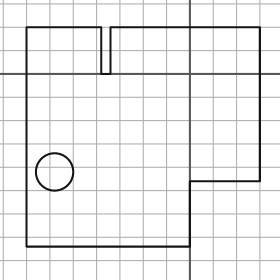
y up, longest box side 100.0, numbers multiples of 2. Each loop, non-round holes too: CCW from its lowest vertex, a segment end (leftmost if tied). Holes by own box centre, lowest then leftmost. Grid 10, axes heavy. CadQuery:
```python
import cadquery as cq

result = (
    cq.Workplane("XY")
    .moveTo(-70.0, -74.0)
    .lineTo(0.0, -74.0)
    .lineTo(0.0, -46.0)
    .lineTo(30.0, -46.0)
    .lineTo(30.0, 20.0)
    .lineTo(-34.0, 20.0)
    .lineTo(-34.0, 0.0)
    .lineTo(-38.0, 0.0)
    .lineTo(-38.0, 20.0)
    .lineTo(-70.0, 20.0)
    .close()
    .moveTo(-58.0, -42.0)
    .circle(8.0)
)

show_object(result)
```